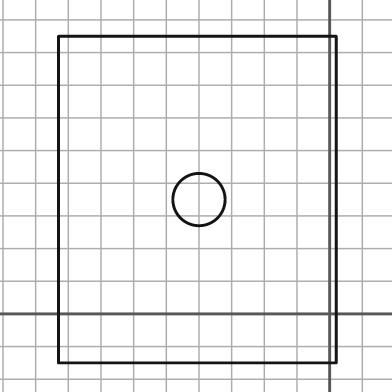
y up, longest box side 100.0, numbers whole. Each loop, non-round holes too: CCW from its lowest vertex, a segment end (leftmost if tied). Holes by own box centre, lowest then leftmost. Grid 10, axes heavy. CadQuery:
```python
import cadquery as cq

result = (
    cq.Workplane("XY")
    .moveTo(-83.0, -15.0)
    .lineTo(2.0, -15.0)
    .lineTo(2.0, 85.0)
    .lineTo(-83.0, 85.0)
    .close()
    .moveTo(-40.0, 35.0)
    .circle(8.0)
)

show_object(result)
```